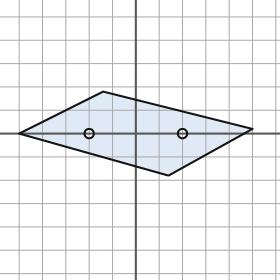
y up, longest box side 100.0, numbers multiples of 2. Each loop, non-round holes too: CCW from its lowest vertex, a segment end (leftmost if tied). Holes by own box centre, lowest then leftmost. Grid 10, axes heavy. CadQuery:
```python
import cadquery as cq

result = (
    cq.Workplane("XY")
    .moveTo(14.0, -18.0)
    .lineTo(50.0, 2.0)
    .lineTo(-14.0, 18.0)
    .lineTo(-50.0, 0.0)
    .close()
    .moveTo(-20.0, 0.0)
    .circle(2.0)
    .moveTo(20.0, 0.0)
    .circle(2.0)
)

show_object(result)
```